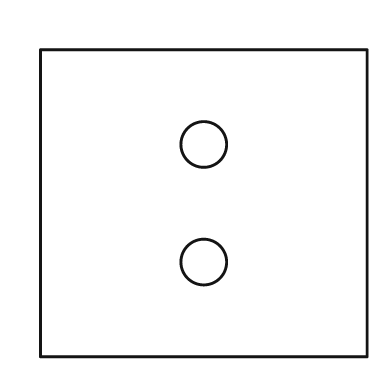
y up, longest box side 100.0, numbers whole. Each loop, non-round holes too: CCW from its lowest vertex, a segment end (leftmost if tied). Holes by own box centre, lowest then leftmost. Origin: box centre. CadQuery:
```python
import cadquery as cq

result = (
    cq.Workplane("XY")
    .moveTo(-50.0, -47.0)
    .lineTo(50.0, -47.0)
    .lineTo(50.0, 47.0)
    .lineTo(-50.0, 47.0)
    .close()
    .moveTo(0.0, -18.0)
    .circle(7.0)
    .moveTo(0.0, 18.0)
    .circle(7.0)
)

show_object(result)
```